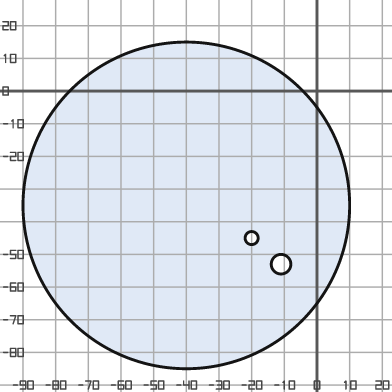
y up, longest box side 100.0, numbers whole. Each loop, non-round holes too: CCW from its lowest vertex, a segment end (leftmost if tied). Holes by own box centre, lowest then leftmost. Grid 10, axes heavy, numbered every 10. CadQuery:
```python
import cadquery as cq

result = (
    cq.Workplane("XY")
    .moveTo(-40.0, -35.0)
    .circle(50.0)
    .moveTo(-11.0, -53.0)
    .circle(3.0)
    .moveTo(-20.0, -45.0)
    .circle(2.0)
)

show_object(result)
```